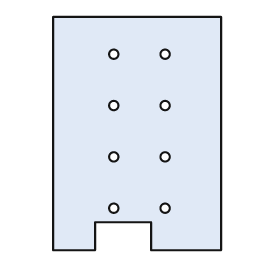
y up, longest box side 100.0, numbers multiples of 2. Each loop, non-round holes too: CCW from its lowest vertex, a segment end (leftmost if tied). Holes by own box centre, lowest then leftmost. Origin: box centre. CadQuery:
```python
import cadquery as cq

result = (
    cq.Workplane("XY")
    .moveTo(-36.0, -50.0)
    .lineTo(-18.0, -50.0)
    .lineTo(-18.0, -38.0)
    .lineTo(6.0, -38.0)
    .lineTo(6.0, -50.0)
    .lineTo(36.0, -50.0)
    .lineTo(36.0, 50.0)
    .lineTo(-36.0, 50.0)
    .close()
    .moveTo(-10.0, -32.0)
    .circle(2.0)
    .moveTo(12.0, -32.0)
    .circle(2.0)
    .moveTo(-10.0, -10.0)
    .circle(2.0)
    .moveTo(12.0, -10.0)
    .circle(2.0)
    .moveTo(-10.0, 12.0)
    .circle(2.0)
    .moveTo(12.0, 12.0)
    .circle(2.0)
    .moveTo(-10.0, 34.0)
    .circle(2.0)
    .moveTo(12.0, 34.0)
    .circle(2.0)
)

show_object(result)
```